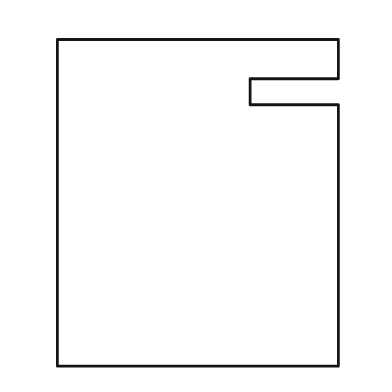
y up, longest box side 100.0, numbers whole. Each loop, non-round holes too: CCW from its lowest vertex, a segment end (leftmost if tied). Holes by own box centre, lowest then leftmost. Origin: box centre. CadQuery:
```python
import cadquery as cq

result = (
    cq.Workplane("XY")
    .moveTo(-43.0, -50.0)
    .lineTo(43.0, -50.0)
    .lineTo(43.0, 30.0)
    .lineTo(16.0, 30.0)
    .lineTo(16.0, 38.0)
    .lineTo(43.0, 38.0)
    .lineTo(43.0, 50.0)
    .lineTo(-43.0, 50.0)
    .close()
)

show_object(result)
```